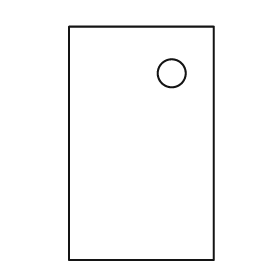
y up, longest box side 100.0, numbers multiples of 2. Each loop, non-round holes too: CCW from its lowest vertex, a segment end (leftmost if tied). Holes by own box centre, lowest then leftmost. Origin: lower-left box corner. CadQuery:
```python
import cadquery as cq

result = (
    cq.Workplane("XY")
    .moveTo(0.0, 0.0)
    .lineTo(62.0, 0.0)
    .lineTo(62.0, 100.0)
    .lineTo(0.0, 100.0)
    .close()
    .moveTo(44.0, 80.0)
    .circle(6.0)
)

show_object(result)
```